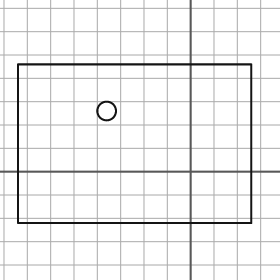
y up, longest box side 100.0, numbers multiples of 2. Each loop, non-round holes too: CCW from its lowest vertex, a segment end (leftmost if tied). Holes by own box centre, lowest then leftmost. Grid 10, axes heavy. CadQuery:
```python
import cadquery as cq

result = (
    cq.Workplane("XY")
    .moveTo(-74.0, -22.0)
    .lineTo(26.0, -22.0)
    .lineTo(26.0, 46.0)
    .lineTo(-74.0, 46.0)
    .close()
    .moveTo(-36.0, 26.0)
    .circle(4.0)
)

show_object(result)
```